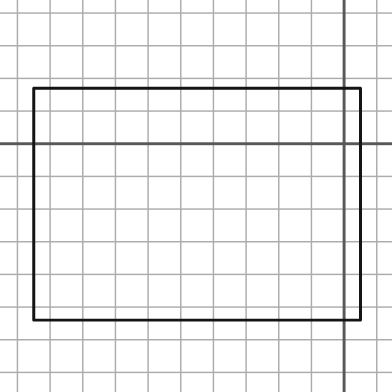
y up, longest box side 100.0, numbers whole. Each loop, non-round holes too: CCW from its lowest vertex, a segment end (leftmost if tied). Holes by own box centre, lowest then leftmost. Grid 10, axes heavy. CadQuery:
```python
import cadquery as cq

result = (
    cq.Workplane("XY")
    .moveTo(-95.0, -54.0)
    .lineTo(5.0, -54.0)
    .lineTo(5.0, 17.0)
    .lineTo(-95.0, 17.0)
    .close()
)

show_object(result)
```